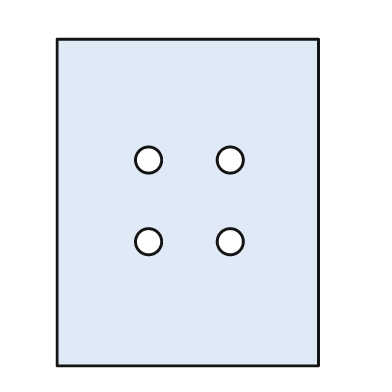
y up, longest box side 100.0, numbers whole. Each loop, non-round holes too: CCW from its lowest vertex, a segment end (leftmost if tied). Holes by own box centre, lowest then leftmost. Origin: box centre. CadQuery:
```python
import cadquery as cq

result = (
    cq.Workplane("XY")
    .moveTo(-40.0, -50.0)
    .lineTo(40.0, -50.0)
    .lineTo(40.0, 50.0)
    .lineTo(-40.0, 50.0)
    .close()
    .moveTo(-12.0, -12.0)
    .circle(4.0)
    .moveTo(13.0, -12.0)
    .circle(4.0)
    .moveTo(-12.0, 13.0)
    .circle(4.0)
    .moveTo(13.0, 13.0)
    .circle(4.0)
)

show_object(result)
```